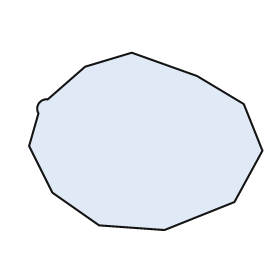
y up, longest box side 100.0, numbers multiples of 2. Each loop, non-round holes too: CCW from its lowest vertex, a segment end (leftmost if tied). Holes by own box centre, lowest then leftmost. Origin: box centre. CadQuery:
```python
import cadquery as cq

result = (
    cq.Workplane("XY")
    .moveTo(8.0, -38.0)
    .lineTo(38.0, -26.0)
    .lineTo(50.0, -4.0)
    .lineTo(42.0, 16.0)
    .lineTo(22.0, 28.0)
    .lineTo(-6.0, 38.0)
    .lineTo(-26.0, 32.0)
    .lineTo(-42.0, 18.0)
    .threePointArc((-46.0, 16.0), (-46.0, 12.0))
    .lineTo(-50.0, -2.0)
    .lineTo(-40.0, -22.0)
    .lineTo(-20.0, -36.0)
    .close()
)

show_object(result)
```